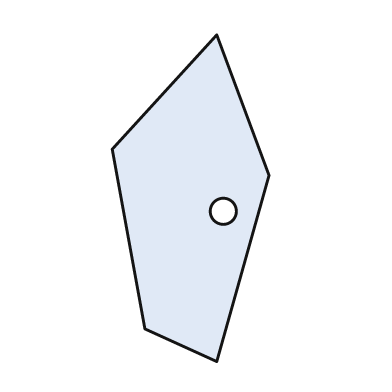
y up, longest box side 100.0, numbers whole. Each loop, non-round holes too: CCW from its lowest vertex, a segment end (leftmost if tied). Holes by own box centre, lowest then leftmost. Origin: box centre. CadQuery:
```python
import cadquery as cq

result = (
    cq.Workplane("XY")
    .moveTo(8.0, -50.0)
    .lineTo(24.0, 7.0)
    .lineTo(8.0, 50.0)
    .lineTo(-24.0, 15.0)
    .lineTo(-14.0, -40.0)
    .close()
    .moveTo(10.0, -4.0)
    .circle(4.0)
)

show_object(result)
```